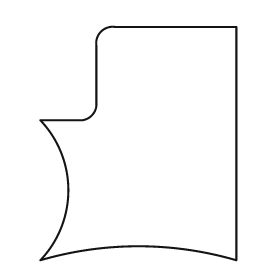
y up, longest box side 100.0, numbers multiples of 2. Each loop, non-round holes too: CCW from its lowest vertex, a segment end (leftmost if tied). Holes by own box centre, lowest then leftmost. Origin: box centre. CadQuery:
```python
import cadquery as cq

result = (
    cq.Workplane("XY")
    .moveTo(-42.0, -50.0)
    .threePointArc((0.0, -44.0), (42.0, -50.0))
    .lineTo(42.0, 50.0)
    .lineTo(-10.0, 50.0)
    .threePointArc((-16.0, 48.0), (-18.0, 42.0))
    .lineTo(-18.0, 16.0)
    .threePointArc((-20.0, 12.0), (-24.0, 10.0))
    .lineTo(-42.0, 10.0)
    .threePointArc((-30.0, -20.0), (-42.0, -50.0))
    .close()
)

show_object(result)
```